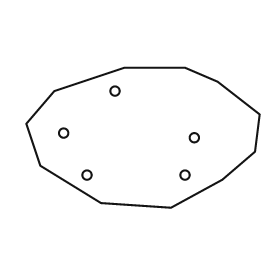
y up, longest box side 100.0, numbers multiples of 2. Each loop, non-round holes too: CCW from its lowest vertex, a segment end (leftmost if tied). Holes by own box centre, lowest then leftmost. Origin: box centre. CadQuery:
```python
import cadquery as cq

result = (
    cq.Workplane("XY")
    .moveTo(12.0, -30.0)
    .lineTo(34.0, -18.0)
    .lineTo(48.0, -6.0)
    .lineTo(50.0, 10.0)
    .lineTo(32.0, 24.0)
    .lineTo(18.0, 30.0)
    .lineTo(-8.0, 30.0)
    .lineTo(-38.0, 20.0)
    .lineTo(-50.0, 6.0)
    .lineTo(-44.0, -12.0)
    .lineTo(-18.0, -28.0)
    .close()
    .moveTo(-24.0, -16.0)
    .circle(2.0)
    .moveTo(18.0, -16.0)
    .circle(2.0)
    .moveTo(22.0, 0.0)
    .circle(2.0)
    .moveTo(-34.0, 2.0)
    .circle(2.0)
    .moveTo(-12.0, 20.0)
    .circle(2.0)
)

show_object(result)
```